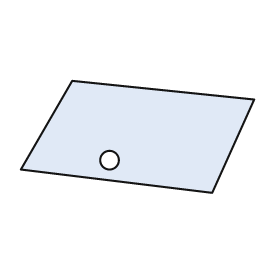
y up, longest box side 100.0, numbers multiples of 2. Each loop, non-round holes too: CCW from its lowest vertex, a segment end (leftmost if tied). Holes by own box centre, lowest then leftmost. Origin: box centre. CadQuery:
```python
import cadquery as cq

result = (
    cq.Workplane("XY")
    .moveTo(32.0, -24.0)
    .lineTo(50.0, 16.0)
    .lineTo(-28.0, 24.0)
    .lineTo(-50.0, -14.0)
    .close()
    .moveTo(-12.0, -10.0)
    .circle(4.0)
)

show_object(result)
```